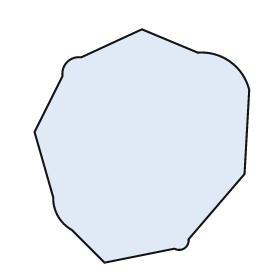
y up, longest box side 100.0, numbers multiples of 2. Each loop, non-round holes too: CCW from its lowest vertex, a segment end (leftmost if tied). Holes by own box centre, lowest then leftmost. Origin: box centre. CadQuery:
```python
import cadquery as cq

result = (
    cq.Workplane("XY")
    .moveTo(-16.0, -50.0)
    .lineTo(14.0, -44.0)
    .threePointArc((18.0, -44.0), (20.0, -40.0))
    .lineTo(44.0, -12.0)
    .lineTo(46.0, 24.0)
    .threePointArc((38.0, 36.0), (24.0, 40.0))
    .lineTo(0.0, 50.0)
    .lineTo(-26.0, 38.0)
    .threePointArc((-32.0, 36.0), (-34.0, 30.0))
    .lineTo(-46.0, 6.0)
    .lineTo(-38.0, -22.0)
    .threePointArc((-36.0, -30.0), (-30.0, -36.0))
    .close()
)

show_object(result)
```